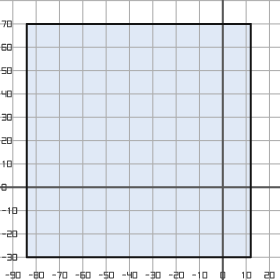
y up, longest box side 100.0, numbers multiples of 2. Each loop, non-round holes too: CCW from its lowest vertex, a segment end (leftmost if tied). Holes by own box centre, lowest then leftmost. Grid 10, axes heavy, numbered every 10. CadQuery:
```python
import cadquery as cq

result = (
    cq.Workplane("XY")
    .moveTo(-84.0, -30.0)
    .lineTo(12.0, -30.0)
    .lineTo(12.0, 70.0)
    .lineTo(-84.0, 70.0)
    .close()
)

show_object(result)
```